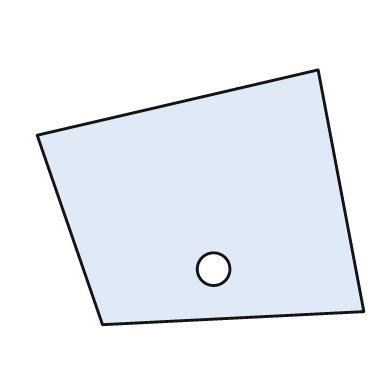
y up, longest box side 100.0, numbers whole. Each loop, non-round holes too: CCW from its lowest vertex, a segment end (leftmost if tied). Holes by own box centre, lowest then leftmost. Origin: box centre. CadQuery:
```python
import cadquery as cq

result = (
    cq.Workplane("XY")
    .moveTo(-30.0, -39.0)
    .lineTo(50.0, -35.0)
    .lineTo(36.0, 39.0)
    .lineTo(-50.0, 19.0)
    .close()
    .moveTo(4.0, -22.0)
    .circle(5.0)
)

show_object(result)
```